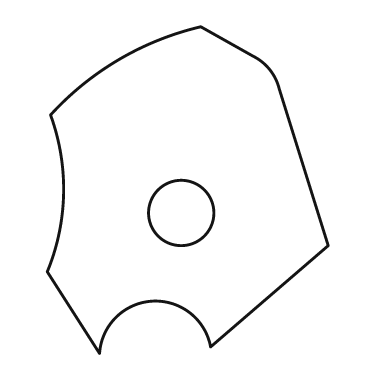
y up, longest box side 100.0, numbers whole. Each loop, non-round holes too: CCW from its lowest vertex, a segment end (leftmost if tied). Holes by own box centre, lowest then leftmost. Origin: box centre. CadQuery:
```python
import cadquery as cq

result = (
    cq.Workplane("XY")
    .moveTo(-27.0, -50.0)
    .threePointArc((-11.0, -34.0), (7.0, -48.0))
    .lineTo(43.0, -17.0)
    .lineTo(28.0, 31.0)
    .threePointArc((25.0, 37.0), (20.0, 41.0))
    .lineTo(4.0, 50.0)
    .threePointArc((-21.0, 40.0), (-42.0, 23.0))
    .threePointArc((-38.0, -1.0), (-43.0, -25.0))
    .close()
    .moveTo(-2.0, -7.0)
    .circle(10.0)
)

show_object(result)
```